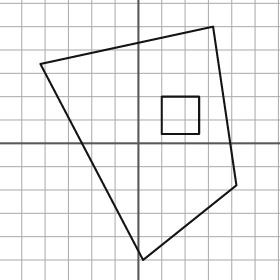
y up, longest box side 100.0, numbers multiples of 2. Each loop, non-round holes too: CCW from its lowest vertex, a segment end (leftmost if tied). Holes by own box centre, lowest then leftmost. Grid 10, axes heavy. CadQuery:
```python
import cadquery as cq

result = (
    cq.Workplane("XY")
    .moveTo(2.0, -50.0)
    .lineTo(42.0, -18.0)
    .lineTo(32.0, 50.0)
    .lineTo(-42.0, 34.0)
    .close()
    .moveTo(10.0, 4.0)
    .lineTo(26.0, 4.0)
    .lineTo(26.0, 20.0)
    .lineTo(10.0, 20.0)
    .close()
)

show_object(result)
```